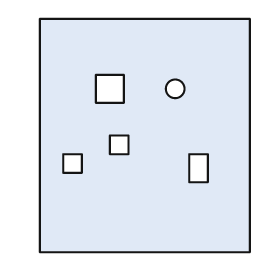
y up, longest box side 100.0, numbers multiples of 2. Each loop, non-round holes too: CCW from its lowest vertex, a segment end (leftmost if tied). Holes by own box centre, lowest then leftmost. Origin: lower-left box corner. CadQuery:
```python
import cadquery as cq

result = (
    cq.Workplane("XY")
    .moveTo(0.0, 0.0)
    .lineTo(90.0, 0.0)
    .lineTo(90.0, 100.0)
    .lineTo(0.0, 100.0)
    .close()
    .moveTo(64.0, 30.0)
    .lineTo(72.0, 30.0)
    .lineTo(72.0, 42.0)
    .lineTo(64.0, 42.0)
    .close()
    .moveTo(10.0, 34.0)
    .lineTo(18.0, 34.0)
    .lineTo(18.0, 42.0)
    .lineTo(10.0, 42.0)
    .close()
    .moveTo(30.0, 42.0)
    .lineTo(38.0, 42.0)
    .lineTo(38.0, 50.0)
    .lineTo(30.0, 50.0)
    .close()
    .moveTo(24.0, 64.0)
    .lineTo(36.0, 64.0)
    .lineTo(36.0, 76.0)
    .lineTo(24.0, 76.0)
    .close()
    .moveTo(58.0, 70.0)
    .circle(4.0)
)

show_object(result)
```